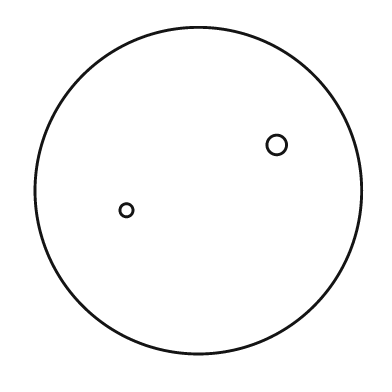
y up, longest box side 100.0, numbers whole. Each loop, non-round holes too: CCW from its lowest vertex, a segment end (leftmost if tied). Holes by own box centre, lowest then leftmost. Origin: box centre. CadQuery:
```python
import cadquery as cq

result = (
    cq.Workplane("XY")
    .moveTo(0.0, 0.0)
    .circle(50.0)
    .moveTo(-22.0, -6.0)
    .circle(2.0)
    .moveTo(24.0, 14.0)
    .circle(3.0)
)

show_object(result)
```